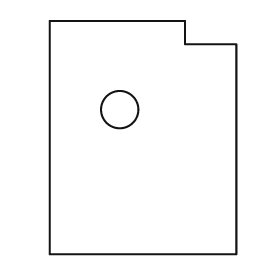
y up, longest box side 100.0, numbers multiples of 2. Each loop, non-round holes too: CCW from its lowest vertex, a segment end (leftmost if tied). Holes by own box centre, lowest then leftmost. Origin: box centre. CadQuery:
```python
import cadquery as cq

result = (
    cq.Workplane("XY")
    .moveTo(-40.0, -50.0)
    .lineTo(40.0, -50.0)
    .lineTo(40.0, 40.0)
    .lineTo(18.0, 40.0)
    .lineTo(18.0, 50.0)
    .lineTo(-40.0, 50.0)
    .close()
    .moveTo(-10.0, 12.0)
    .circle(8.0)
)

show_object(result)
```